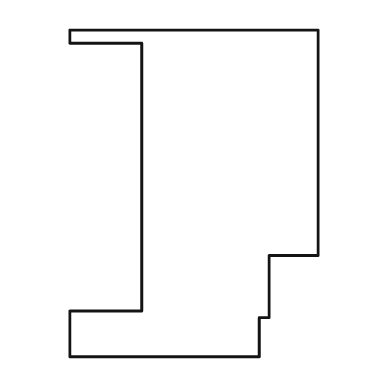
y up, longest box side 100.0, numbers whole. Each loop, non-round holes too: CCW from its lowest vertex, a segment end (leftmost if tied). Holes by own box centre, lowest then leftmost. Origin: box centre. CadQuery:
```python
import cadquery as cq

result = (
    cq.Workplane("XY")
    .moveTo(-38.0, -50.0)
    .lineTo(20.0, -50.0)
    .lineTo(20.0, -38.0)
    .lineTo(23.0, -38.0)
    .lineTo(23.0, -19.0)
    .lineTo(38.0, -19.0)
    .lineTo(38.0, 50.0)
    .lineTo(-38.0, 50.0)
    .lineTo(-38.0, 46.0)
    .lineTo(-16.0, 46.0)
    .lineTo(-16.0, -36.0)
    .lineTo(-38.0, -36.0)
    .close()
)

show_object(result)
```